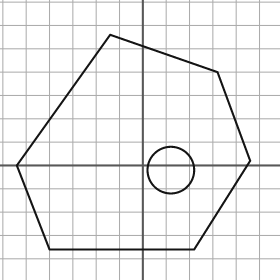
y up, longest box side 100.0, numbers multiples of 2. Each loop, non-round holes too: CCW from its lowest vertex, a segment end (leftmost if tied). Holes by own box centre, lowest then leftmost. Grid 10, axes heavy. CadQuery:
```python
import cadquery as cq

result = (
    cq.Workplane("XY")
    .moveTo(-40.0, -36.0)
    .lineTo(22.0, -36.0)
    .lineTo(46.0, 2.0)
    .lineTo(32.0, 40.0)
    .lineTo(-14.0, 56.0)
    .lineTo(-54.0, 0.0)
    .close()
    .moveTo(12.0, -2.0)
    .circle(10.0)
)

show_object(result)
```